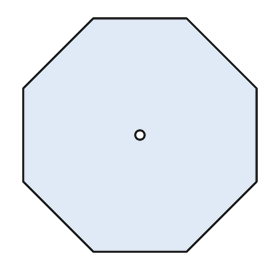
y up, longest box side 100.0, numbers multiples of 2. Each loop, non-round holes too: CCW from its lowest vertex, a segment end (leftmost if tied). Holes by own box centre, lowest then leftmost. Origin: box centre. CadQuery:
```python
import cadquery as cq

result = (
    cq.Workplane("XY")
    .moveTo(-20.0, -50.0)
    .lineTo(20.0, -50.0)
    .lineTo(50.0, -20.0)
    .lineTo(50.0, 20.0)
    .lineTo(20.0, 50.0)
    .lineTo(-20.0, 50.0)
    .lineTo(-50.0, 20.0)
    .lineTo(-50.0, -20.0)
    .close()
    .moveTo(0.0, 0.0)
    .circle(2.0)
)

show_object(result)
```